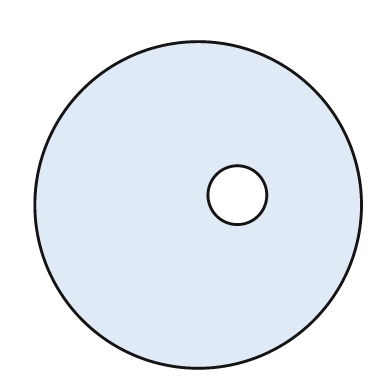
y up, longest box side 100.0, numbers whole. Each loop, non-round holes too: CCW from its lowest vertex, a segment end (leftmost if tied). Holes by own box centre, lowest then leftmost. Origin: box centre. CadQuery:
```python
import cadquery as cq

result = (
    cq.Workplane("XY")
    .moveTo(0.0, 0.0)
    .circle(50.0)
    .moveTo(12.0, 3.0)
    .circle(9.0)
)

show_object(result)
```